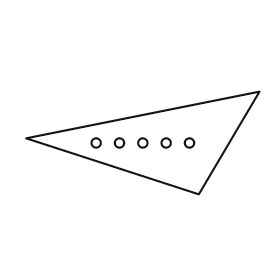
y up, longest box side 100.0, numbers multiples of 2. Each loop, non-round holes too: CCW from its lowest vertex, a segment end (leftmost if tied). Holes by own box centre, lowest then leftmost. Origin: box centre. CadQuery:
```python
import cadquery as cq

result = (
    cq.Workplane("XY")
    .moveTo(24.0, -22.0)
    .lineTo(50.0, 22.0)
    .lineTo(-50.0, 2.0)
    .close()
    .moveTo(-20.0, 0.0)
    .circle(2.0)
    .moveTo(-10.0, 0.0)
    .circle(2.0)
    .moveTo(0.0, 0.0)
    .circle(2.0)
    .moveTo(10.0, 0.0)
    .circle(2.0)
    .moveTo(20.0, 0.0)
    .circle(2.0)
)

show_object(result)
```